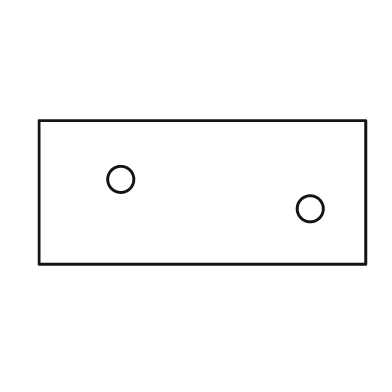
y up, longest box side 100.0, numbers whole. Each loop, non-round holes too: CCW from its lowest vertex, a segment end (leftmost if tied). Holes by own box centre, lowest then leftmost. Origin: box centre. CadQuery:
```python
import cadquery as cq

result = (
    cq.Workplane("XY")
    .moveTo(-50.0, -22.0)
    .lineTo(50.0, -22.0)
    .lineTo(50.0, 22.0)
    .lineTo(-50.0, 22.0)
    .close()
    .moveTo(33.0, -5.0)
    .circle(4.0)
    .moveTo(-25.0, 4.0)
    .circle(4.0)
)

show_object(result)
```